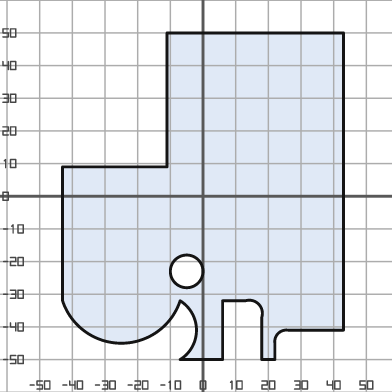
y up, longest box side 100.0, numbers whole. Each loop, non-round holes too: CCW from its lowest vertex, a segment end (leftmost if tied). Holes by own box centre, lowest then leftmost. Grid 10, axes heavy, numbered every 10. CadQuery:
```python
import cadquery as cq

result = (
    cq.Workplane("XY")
    .moveTo(-7.0, -50.0)
    .lineTo(6.0, -50.0)
    .lineTo(6.0, -32.0)
    .lineTo(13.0, -32.0)
    .threePointArc((17.0, -33.0), (18.0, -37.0))
    .lineTo(18.0, -50.0)
    .lineTo(22.0, -50.0)
    .lineTo(22.0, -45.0)
    .threePointArc((23.0, -42.0), (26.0, -41.0))
    .lineTo(43.0, -41.0)
    .lineTo(43.0, 50.0)
    .lineTo(-11.0, 50.0)
    .lineTo(-11.0, 9.0)
    .lineTo(-43.0, 9.0)
    .lineTo(-43.0, -32.0)
    .threePointArc((-25.0, -45.0), (-7.0, -32.0))
    .threePointArc((-2.0, -41.0), (-7.0, -50.0))
    .close()
    .moveTo(-5.0, -23.0)
    .circle(5.0)
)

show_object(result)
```